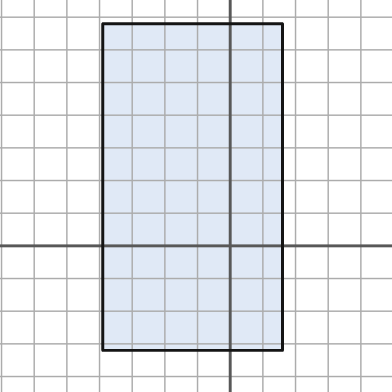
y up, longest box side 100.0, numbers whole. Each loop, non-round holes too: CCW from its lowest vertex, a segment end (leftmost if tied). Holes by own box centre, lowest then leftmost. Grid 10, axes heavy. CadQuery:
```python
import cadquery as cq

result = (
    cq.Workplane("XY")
    .moveTo(-39.0, -32.0)
    .lineTo(16.0, -32.0)
    .lineTo(16.0, 68.0)
    .lineTo(-39.0, 68.0)
    .close()
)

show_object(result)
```